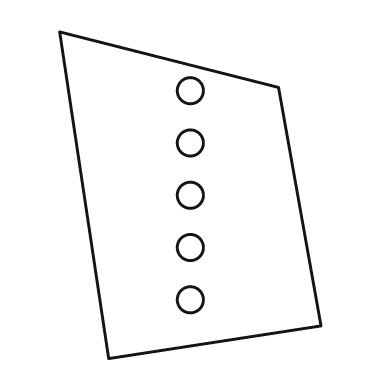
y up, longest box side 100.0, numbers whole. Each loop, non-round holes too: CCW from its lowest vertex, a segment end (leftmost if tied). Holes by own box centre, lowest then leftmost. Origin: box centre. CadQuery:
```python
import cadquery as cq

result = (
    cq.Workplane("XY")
    .moveTo(-25.0, -50.0)
    .lineTo(40.0, -40.0)
    .lineTo(27.0, 33.0)
    .lineTo(-40.0, 50.0)
    .close()
    .moveTo(0.0, -32.0)
    .circle(4.0)
    .moveTo(0.0, -16.0)
    .circle(4.0)
    .moveTo(0.0, 0.0)
    .circle(4.0)
    .moveTo(0.0, 16.0)
    .circle(4.0)
    .moveTo(0.0, 32.0)
    .circle(4.0)
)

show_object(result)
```